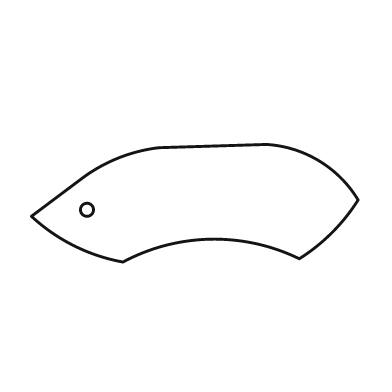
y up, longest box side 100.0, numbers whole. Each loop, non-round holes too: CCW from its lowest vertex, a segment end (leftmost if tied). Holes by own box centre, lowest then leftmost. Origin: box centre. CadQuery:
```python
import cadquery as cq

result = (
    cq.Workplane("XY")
    .moveTo(-22.0, -18.0)
    .threePointArc((5.0, -11.0), (32.0, -17.0))
    .threePointArc((42.0, -9.0), (50.0, 1.0))
    .threePointArc((38.0, 13.0), (22.0, 18.0))
    .lineTo(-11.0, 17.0)
    .threePointArc((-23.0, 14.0), (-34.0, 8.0))
    .lineTo(-50.0, -4.0)
    .threePointArc((-37.0, -13.0), (-22.0, -18.0))
    .close()
    .moveTo(-33.0, -2.0)
    .circle(2.0)
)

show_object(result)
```